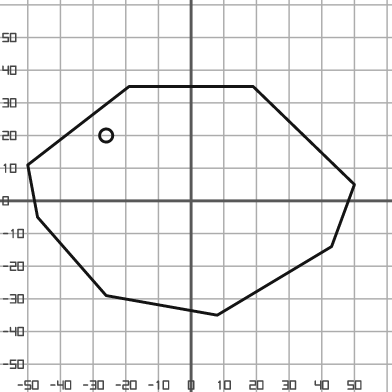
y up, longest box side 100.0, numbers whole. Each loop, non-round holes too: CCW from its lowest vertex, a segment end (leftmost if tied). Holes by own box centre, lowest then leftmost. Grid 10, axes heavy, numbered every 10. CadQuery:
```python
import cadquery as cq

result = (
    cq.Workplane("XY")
    .moveTo(8.0, -35.0)
    .lineTo(43.0, -14.0)
    .lineTo(50.0, 5.0)
    .lineTo(19.0, 35.0)
    .lineTo(-19.0, 35.0)
    .lineTo(-50.0, 11.0)
    .lineTo(-47.0, -5.0)
    .lineTo(-26.0, -29.0)
    .close()
    .moveTo(-26.0, 20.0)
    .circle(2.0)
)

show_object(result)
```